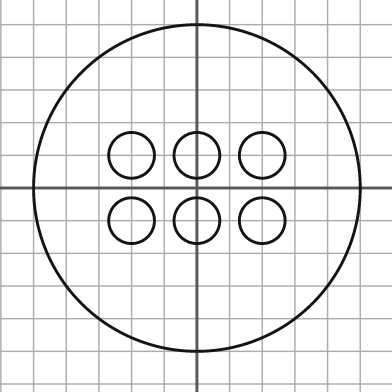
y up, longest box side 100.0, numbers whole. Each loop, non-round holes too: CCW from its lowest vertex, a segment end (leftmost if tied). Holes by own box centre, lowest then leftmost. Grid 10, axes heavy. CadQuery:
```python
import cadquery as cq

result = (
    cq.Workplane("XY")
    .moveTo(0.0, 0.0)
    .circle(50.0)
    .moveTo(-20.0, -10.0)
    .circle(7.0)
    .moveTo(0.0, -10.0)
    .circle(7.0)
    .moveTo(20.0, -10.0)
    .circle(7.0)
    .moveTo(-20.0, 10.0)
    .circle(7.0)
    .moveTo(0.0, 10.0)
    .circle(7.0)
    .moveTo(20.0, 10.0)
    .circle(7.0)
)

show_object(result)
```